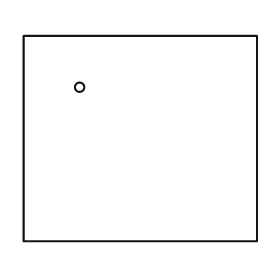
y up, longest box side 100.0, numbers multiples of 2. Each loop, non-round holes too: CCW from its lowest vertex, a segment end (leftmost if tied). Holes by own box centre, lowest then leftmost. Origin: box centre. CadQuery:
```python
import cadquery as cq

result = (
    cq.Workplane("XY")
    .moveTo(-50.0, -44.0)
    .lineTo(50.0, -44.0)
    .lineTo(50.0, 44.0)
    .lineTo(-50.0, 44.0)
    .close()
    .moveTo(-26.0, 22.0)
    .circle(2.0)
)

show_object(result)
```